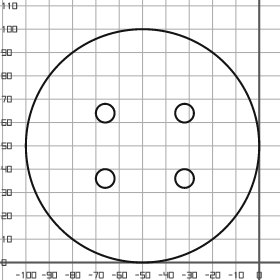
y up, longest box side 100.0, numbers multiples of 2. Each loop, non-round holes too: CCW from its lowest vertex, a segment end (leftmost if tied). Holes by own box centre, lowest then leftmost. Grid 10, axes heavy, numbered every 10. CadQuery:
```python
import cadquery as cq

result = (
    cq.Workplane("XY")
    .moveTo(-50.0, 50.0)
    .circle(50.0)
    .moveTo(-66.0, 36.0)
    .circle(4.0)
    .moveTo(-32.0, 36.0)
    .circle(4.0)
    .moveTo(-66.0, 64.0)
    .circle(4.0)
    .moveTo(-32.0, 64.0)
    .circle(4.0)
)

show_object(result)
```